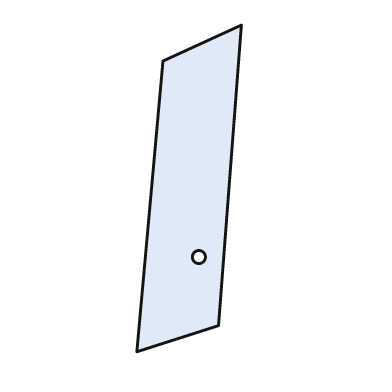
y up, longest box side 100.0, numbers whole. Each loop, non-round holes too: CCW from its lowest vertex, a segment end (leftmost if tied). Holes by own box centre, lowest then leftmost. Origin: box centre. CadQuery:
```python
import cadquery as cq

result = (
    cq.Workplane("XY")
    .moveTo(-16.0, -50.0)
    .lineTo(9.0, -42.0)
    .lineTo(16.0, 50.0)
    .lineTo(-8.0, 39.0)
    .close()
    .moveTo(3.0, -21.0)
    .circle(2.0)
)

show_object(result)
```